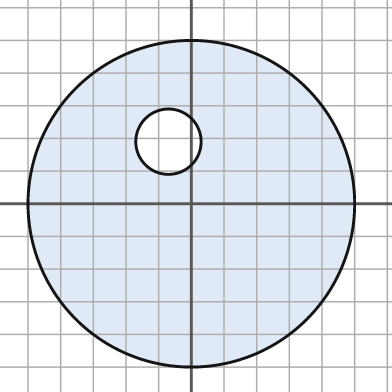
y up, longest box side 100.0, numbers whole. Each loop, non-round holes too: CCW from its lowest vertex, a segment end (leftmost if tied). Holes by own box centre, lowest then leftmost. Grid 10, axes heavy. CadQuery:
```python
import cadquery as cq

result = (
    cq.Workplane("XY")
    .moveTo(0.0, 0.0)
    .circle(50.0)
    .moveTo(-7.0, 19.0)
    .circle(10.0)
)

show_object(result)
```